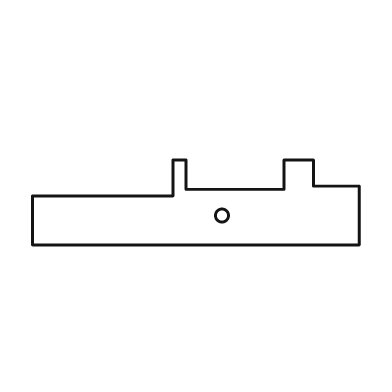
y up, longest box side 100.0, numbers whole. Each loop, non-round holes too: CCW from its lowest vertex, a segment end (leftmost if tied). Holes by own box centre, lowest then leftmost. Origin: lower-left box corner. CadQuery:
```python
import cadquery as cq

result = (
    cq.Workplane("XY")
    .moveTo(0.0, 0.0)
    .lineTo(100.0, 0.0)
    .lineTo(100.0, 18.0)
    .lineTo(86.0, 18.0)
    .lineTo(86.0, 26.0)
    .lineTo(77.0, 26.0)
    .lineTo(77.0, 17.0)
    .lineTo(47.0, 17.0)
    .lineTo(47.0, 26.0)
    .lineTo(43.0, 26.0)
    .lineTo(43.0, 15.0)
    .lineTo(0.0, 15.0)
    .close()
    .moveTo(58.0, 9.0)
    .circle(2.0)
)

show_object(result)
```